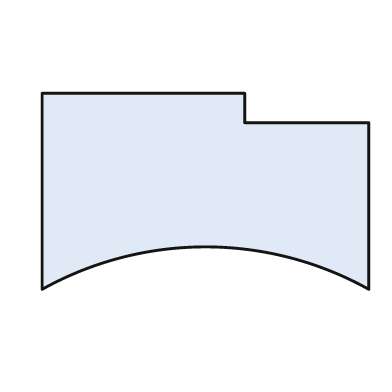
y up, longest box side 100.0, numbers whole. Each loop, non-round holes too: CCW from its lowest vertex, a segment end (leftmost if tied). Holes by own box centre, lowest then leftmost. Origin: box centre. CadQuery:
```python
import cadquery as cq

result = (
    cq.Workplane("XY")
    .moveTo(-50.0, -30.0)
    .threePointArc((0.0, -17.0), (50.0, -30.0))
    .lineTo(50.0, 21.0)
    .lineTo(12.0, 21.0)
    .lineTo(12.0, 30.0)
    .lineTo(-50.0, 30.0)
    .close()
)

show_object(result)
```